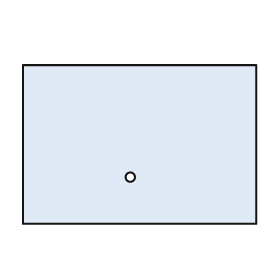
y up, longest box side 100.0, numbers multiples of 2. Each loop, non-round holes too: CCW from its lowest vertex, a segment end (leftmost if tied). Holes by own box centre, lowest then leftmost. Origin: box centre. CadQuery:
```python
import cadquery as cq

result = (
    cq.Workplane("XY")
    .moveTo(-50.0, -34.0)
    .lineTo(50.0, -34.0)
    .lineTo(50.0, 34.0)
    .lineTo(-50.0, 34.0)
    .close()
    .moveTo(-4.0, -14.0)
    .circle(2.0)
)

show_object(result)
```